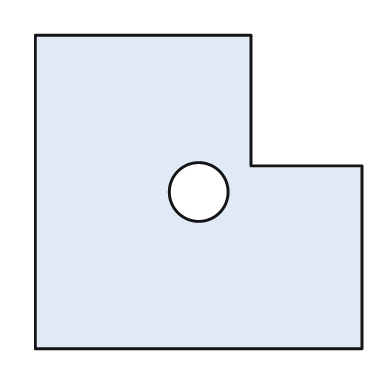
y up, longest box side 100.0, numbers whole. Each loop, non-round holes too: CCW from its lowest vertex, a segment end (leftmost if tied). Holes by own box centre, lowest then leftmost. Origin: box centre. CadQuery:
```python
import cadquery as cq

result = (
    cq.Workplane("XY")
    .moveTo(-50.0, -48.0)
    .lineTo(50.0, -48.0)
    .lineTo(50.0, 8.0)
    .lineTo(16.0, 8.0)
    .lineTo(16.0, 48.0)
    .lineTo(-50.0, 48.0)
    .close()
    .moveTo(0.0, 0.0)
    .circle(9.0)
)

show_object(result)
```